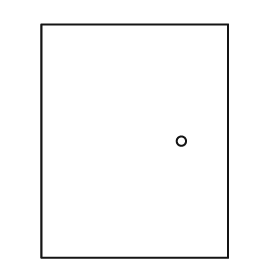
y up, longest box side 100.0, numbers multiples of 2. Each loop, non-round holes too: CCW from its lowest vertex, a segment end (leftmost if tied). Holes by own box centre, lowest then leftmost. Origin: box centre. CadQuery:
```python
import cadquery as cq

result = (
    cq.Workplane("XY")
    .moveTo(-40.0, -50.0)
    .lineTo(40.0, -50.0)
    .lineTo(40.0, 50.0)
    .lineTo(-40.0, 50.0)
    .close()
    .moveTo(20.0, 0.0)
    .circle(2.0)
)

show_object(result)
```